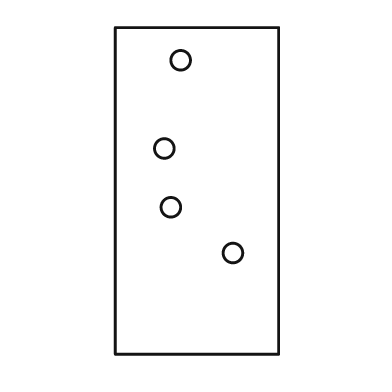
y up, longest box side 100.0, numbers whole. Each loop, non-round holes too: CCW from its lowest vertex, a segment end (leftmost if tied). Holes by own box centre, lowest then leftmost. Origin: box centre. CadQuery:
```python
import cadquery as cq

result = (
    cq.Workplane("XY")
    .moveTo(-25.0, -50.0)
    .lineTo(25.0, -50.0)
    .lineTo(25.0, 50.0)
    .lineTo(-25.0, 50.0)
    .close()
    .moveTo(11.0, -19.0)
    .circle(3.0)
    .moveTo(-8.0, -5.0)
    .circle(3.0)
    .moveTo(-10.0, 13.0)
    .circle(3.0)
    .moveTo(-5.0, 40.0)
    .circle(3.0)
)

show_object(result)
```